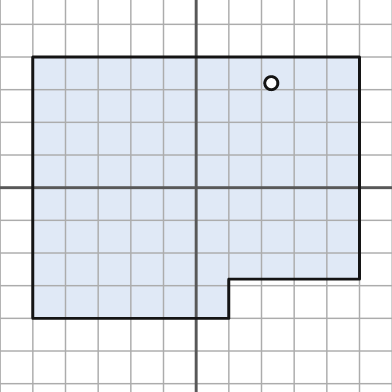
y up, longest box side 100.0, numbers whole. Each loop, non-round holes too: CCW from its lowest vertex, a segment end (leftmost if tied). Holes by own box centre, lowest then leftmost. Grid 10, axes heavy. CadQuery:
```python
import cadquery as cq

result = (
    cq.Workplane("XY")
    .moveTo(-50.0, -40.0)
    .lineTo(10.0, -40.0)
    .lineTo(10.0, -28.0)
    .lineTo(50.0, -28.0)
    .lineTo(50.0, 40.0)
    .lineTo(-50.0, 40.0)
    .close()
    .moveTo(23.0, 32.0)
    .circle(2.0)
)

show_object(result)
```